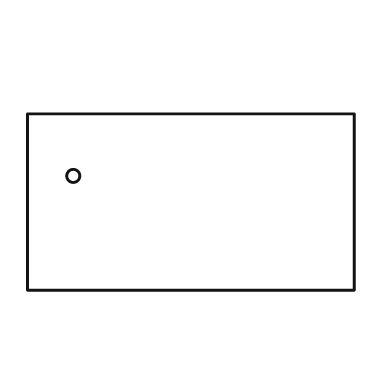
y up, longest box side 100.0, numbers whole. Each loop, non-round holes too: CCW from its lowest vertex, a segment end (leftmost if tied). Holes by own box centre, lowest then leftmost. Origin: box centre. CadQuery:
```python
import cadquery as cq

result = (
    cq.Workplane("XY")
    .moveTo(-50.0, -27.0)
    .lineTo(50.0, -27.0)
    .lineTo(50.0, 27.0)
    .lineTo(-50.0, 27.0)
    .close()
    .moveTo(-36.0, 8.0)
    .circle(2.0)
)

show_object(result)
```